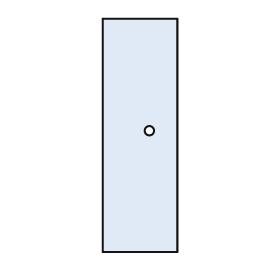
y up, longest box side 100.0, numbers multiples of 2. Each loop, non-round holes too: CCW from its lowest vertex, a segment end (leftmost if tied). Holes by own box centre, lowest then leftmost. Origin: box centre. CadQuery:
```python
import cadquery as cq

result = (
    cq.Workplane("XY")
    .moveTo(-16.0, -50.0)
    .lineTo(16.0, -50.0)
    .lineTo(16.0, 50.0)
    .lineTo(-16.0, 50.0)
    .close()
    .moveTo(4.0, 2.0)
    .circle(2.0)
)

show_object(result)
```